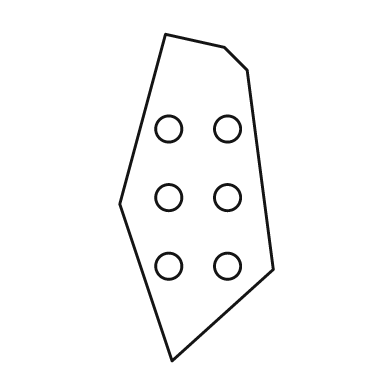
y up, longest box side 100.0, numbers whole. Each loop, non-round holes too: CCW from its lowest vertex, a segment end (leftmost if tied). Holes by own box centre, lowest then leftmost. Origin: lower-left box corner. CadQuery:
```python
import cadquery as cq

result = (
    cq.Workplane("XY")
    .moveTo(16.0, 0.0)
    .lineTo(47.0, 28.0)
    .lineTo(39.0, 89.0)
    .lineTo(32.0, 96.0)
    .lineTo(14.0, 100.0)
    .lineTo(0.0, 48.0)
    .close()
    .moveTo(15.0, 29.0)
    .circle(4.0)
    .moveTo(33.0, 29.0)
    .circle(4.0)
    .moveTo(15.0, 50.0)
    .circle(4.0)
    .moveTo(33.0, 50.0)
    .circle(4.0)
    .moveTo(15.0, 71.0)
    .circle(4.0)
    .moveTo(33.0, 71.0)
    .circle(4.0)
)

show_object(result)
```